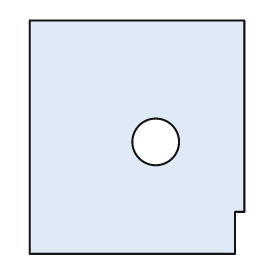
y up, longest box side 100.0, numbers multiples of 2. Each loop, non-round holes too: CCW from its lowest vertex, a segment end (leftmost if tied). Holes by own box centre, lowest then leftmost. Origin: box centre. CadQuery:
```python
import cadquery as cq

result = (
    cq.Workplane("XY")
    .moveTo(-46.0, -50.0)
    .lineTo(42.0, -50.0)
    .lineTo(42.0, -32.0)
    .lineTo(46.0, -32.0)
    .lineTo(46.0, 50.0)
    .lineTo(-46.0, 50.0)
    .close()
    .moveTo(8.0, -2.0)
    .circle(10.0)
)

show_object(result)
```